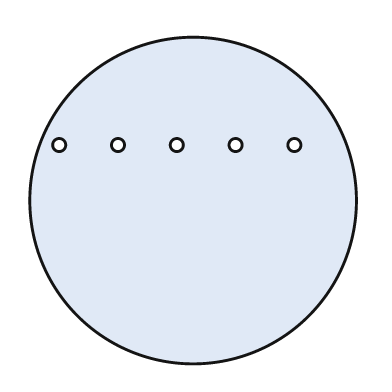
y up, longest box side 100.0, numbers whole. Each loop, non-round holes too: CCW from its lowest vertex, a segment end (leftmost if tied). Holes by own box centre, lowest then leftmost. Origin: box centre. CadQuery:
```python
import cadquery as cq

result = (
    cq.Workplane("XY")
    .moveTo(0.0, 0.0)
    .circle(50.0)
    .moveTo(-41.0, 17.0)
    .circle(2.0)
    .moveTo(-23.0, 17.0)
    .circle(2.0)
    .moveTo(-5.0, 17.0)
    .circle(2.0)
    .moveTo(13.0, 17.0)
    .circle(2.0)
    .moveTo(31.0, 17.0)
    .circle(2.0)
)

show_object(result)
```